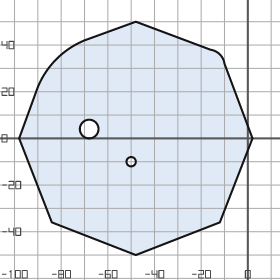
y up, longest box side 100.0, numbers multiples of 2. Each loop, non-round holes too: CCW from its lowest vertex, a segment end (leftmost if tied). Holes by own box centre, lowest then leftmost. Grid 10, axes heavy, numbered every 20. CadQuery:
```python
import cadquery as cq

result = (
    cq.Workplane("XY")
    .moveTo(-48.0, -50.0)
    .lineTo(-12.0, -36.0)
    .lineTo(2.0, 0.0)
    .lineTo(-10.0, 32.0)
    .threePointArc((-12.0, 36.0), (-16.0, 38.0))
    .lineTo(-48.0, 50.0)
    .lineTo(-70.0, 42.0)
    .threePointArc((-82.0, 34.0), (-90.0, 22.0))
    .lineTo(-98.0, 0.0)
    .lineTo(-84.0, -36.0)
    .close()
    .moveTo(-50.0, -10.0)
    .circle(2.0)
    .moveTo(-68.0, 4.0)
    .circle(4.0)
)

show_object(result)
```